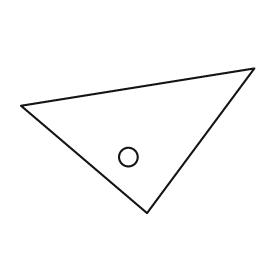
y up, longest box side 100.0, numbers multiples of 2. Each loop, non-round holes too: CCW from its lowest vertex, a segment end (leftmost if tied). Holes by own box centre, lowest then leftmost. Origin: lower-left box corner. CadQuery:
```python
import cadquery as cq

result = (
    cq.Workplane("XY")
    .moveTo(54.0, 0.0)
    .lineTo(100.0, 62.0)
    .lineTo(0.0, 46.0)
    .close()
    .moveTo(46.0, 24.0)
    .circle(4.0)
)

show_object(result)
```